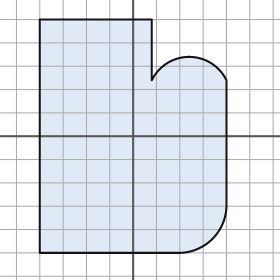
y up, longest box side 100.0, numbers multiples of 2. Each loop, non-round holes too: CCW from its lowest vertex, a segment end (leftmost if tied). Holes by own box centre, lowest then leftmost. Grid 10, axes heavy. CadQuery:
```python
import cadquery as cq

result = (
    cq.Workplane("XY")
    .moveTo(-40.0, -50.0)
    .lineTo(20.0, -50.0)
    .threePointArc((34.0, -44.0), (40.0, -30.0))
    .lineTo(40.0, 24.0)
    .threePointArc((24.0, 34.0), (8.0, 24.0))
    .lineTo(8.0, 50.0)
    .lineTo(-40.0, 50.0)
    .close()
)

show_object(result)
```